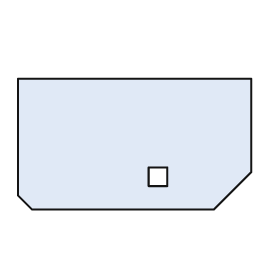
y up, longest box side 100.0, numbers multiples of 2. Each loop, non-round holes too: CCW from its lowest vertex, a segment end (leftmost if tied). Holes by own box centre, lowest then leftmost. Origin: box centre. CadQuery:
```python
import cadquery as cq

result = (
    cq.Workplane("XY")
    .moveTo(-44.0, -28.0)
    .lineTo(34.0, -28.0)
    .lineTo(50.0, -12.0)
    .lineTo(50.0, 28.0)
    .lineTo(-50.0, 28.0)
    .lineTo(-50.0, -22.0)
    .close()
    .moveTo(6.0, -18.0)
    .lineTo(14.0, -18.0)
    .lineTo(14.0, -10.0)
    .lineTo(6.0, -10.0)
    .close()
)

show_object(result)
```